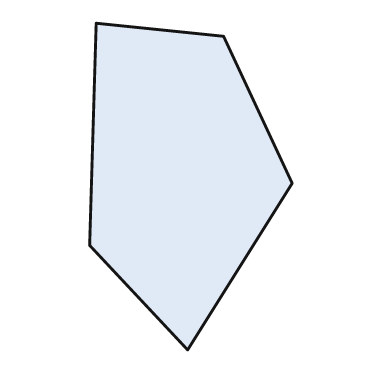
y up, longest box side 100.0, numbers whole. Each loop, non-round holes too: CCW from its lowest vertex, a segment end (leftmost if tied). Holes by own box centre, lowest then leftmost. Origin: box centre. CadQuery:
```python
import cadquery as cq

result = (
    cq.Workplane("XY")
    .moveTo(-1.0, -50.0)
    .lineTo(31.0, 1.0)
    .lineTo(10.0, 46.0)
    .lineTo(-29.0, 50.0)
    .lineTo(-31.0, -18.0)
    .close()
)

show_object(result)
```